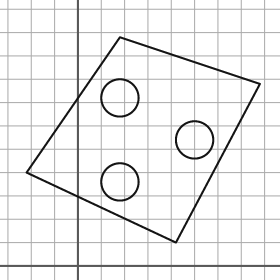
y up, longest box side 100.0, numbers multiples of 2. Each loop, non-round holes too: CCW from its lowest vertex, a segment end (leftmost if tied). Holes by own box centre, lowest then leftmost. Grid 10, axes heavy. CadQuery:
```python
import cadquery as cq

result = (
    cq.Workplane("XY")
    .moveTo(42.0, 10.0)
    .lineTo(78.0, 78.0)
    .lineTo(18.0, 98.0)
    .lineTo(-22.0, 40.0)
    .close()
    .moveTo(18.0, 36.0)
    .circle(8.0)
    .moveTo(50.0, 54.0)
    .circle(8.0)
    .moveTo(18.0, 72.0)
    .circle(8.0)
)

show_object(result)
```